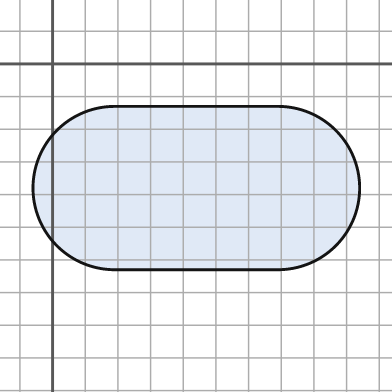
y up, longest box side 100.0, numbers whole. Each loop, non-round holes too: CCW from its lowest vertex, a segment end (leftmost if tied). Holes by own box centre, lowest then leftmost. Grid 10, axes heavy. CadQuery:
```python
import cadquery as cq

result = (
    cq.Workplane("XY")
    .moveTo(19.0, -63.0)
    .lineTo(69.0, -63.0)
    .threePointArc((94.0, -38.0), (69.0, -13.0))
    .lineTo(19.0, -13.0)
    .threePointArc((-6.0, -38.0), (19.0, -63.0))
    .close()
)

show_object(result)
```